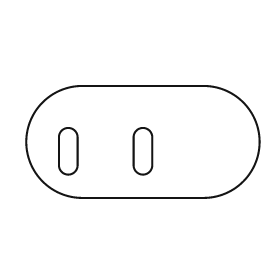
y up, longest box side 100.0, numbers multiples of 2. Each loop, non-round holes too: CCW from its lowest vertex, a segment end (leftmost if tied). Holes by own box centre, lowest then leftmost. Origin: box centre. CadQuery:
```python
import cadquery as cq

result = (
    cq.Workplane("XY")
    .moveTo(-26.0, -24.0)
    .lineTo(26.0, -24.0)
    .threePointArc((50.0, 0.0), (26.0, 24.0))
    .lineTo(-26.0, 24.0)
    .threePointArc((-50.0, 0.0), (-26.0, -24.0))
    .close()
    .moveTo(-36.0, -10.0)
    .threePointArc((-32.0, -14.0), (-28.0, -10.0))
    .lineTo(-28.0, 2.0)
    .threePointArc((-32.0, 6.0), (-36.0, 2.0))
    .close()
    .moveTo(-4.0, -10.0)
    .threePointArc((0.0, -14.0), (4.0, -10.0))
    .lineTo(4.0, 2.0)
    .threePointArc((0.0, 6.0), (-4.0, 2.0))
    .close()
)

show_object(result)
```